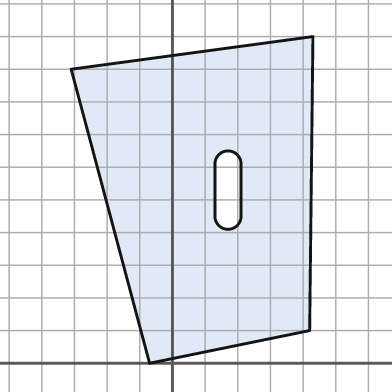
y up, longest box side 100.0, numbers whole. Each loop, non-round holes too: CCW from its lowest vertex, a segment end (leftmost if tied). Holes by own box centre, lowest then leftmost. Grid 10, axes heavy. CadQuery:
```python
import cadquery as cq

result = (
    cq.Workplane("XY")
    .moveTo(-7.0, 0.0)
    .lineTo(42.0, 10.0)
    .lineTo(43.0, 100.0)
    .lineTo(-31.0, 90.0)
    .close()
    .moveTo(13.0, 45.0)
    .threePointArc((17.0, 41.0), (21.0, 45.0))
    .lineTo(21.0, 61.0)
    .threePointArc((17.0, 65.0), (13.0, 61.0))
    .close()
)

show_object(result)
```